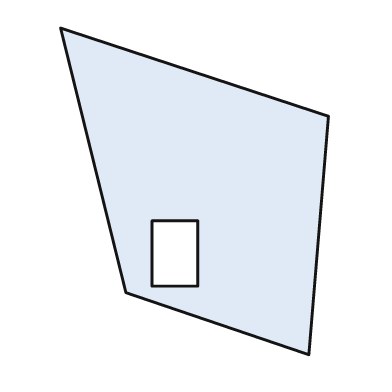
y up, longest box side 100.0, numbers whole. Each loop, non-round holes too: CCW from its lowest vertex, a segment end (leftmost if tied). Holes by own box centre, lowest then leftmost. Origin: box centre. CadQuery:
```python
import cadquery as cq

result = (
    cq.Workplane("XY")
    .moveTo(35.0, -50.0)
    .lineTo(41.0, 23.0)
    .lineTo(-41.0, 50.0)
    .lineTo(-21.0, -31.0)
    .close()
    .moveTo(-13.0, -29.0)
    .lineTo(1.0, -29.0)
    .lineTo(1.0, -9.0)
    .lineTo(-13.0, -9.0)
    .close()
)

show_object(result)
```